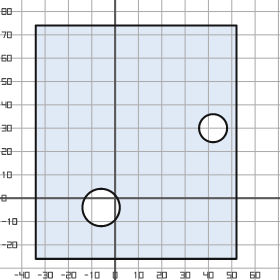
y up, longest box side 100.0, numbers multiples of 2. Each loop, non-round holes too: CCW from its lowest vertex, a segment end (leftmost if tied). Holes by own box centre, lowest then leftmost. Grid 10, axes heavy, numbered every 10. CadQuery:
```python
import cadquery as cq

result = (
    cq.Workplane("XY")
    .moveTo(-34.0, -26.0)
    .lineTo(52.0, -26.0)
    .lineTo(52.0, 74.0)
    .lineTo(-34.0, 74.0)
    .close()
    .moveTo(-6.0, -4.0)
    .circle(8.0)
    .moveTo(42.0, 30.0)
    .circle(6.0)
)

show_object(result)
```